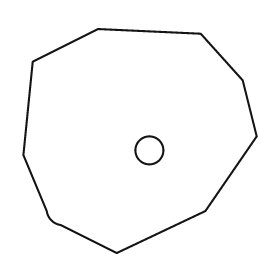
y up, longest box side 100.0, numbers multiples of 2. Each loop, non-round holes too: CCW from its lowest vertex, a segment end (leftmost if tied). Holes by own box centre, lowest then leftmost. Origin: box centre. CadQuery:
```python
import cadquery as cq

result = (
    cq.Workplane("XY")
    .moveTo(-10.0, -48.0)
    .lineTo(28.0, -30.0)
    .lineTo(50.0, 2.0)
    .lineTo(44.0, 26.0)
    .lineTo(26.0, 46.0)
    .lineTo(-18.0, 48.0)
    .lineTo(-46.0, 34.0)
    .lineTo(-50.0, -6.0)
    .lineTo(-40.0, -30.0)
    .threePointArc((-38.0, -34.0), (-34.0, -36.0))
    .close()
    .moveTo(4.0, -4.0)
    .circle(6.0)
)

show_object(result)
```